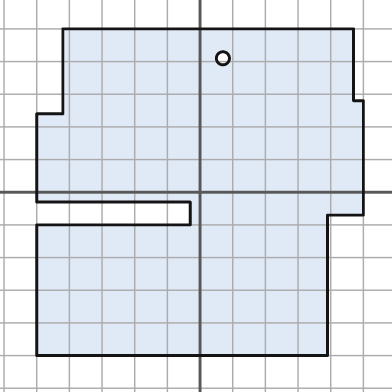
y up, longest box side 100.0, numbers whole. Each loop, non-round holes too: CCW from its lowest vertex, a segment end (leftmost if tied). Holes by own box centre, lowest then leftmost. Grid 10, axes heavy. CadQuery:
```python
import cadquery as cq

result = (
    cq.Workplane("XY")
    .moveTo(-50.0, -50.0)
    .lineTo(39.0, -50.0)
    .lineTo(39.0, -7.0)
    .lineTo(50.0, -7.0)
    .lineTo(50.0, 28.0)
    .lineTo(47.0, 28.0)
    .lineTo(47.0, 50.0)
    .lineTo(-42.0, 50.0)
    .lineTo(-42.0, 24.0)
    .lineTo(-50.0, 24.0)
    .lineTo(-50.0, -3.0)
    .lineTo(-3.0, -3.0)
    .lineTo(-3.0, -10.0)
    .lineTo(-50.0, -10.0)
    .close()
    .moveTo(7.0, 41.0)
    .circle(2.0)
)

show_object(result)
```